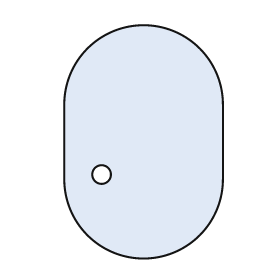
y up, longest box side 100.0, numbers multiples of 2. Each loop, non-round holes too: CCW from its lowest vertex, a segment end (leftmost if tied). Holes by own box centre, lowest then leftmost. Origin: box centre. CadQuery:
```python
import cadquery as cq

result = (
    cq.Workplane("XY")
    .moveTo(-34.0, -16.0)
    .threePointArc((0.0, -50.0), (34.0, -16.0))
    .lineTo(34.0, 16.0)
    .threePointArc((0.0, 50.0), (-34.0, 16.0))
    .close()
    .moveTo(-18.0, -14.0)
    .circle(4.0)
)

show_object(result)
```